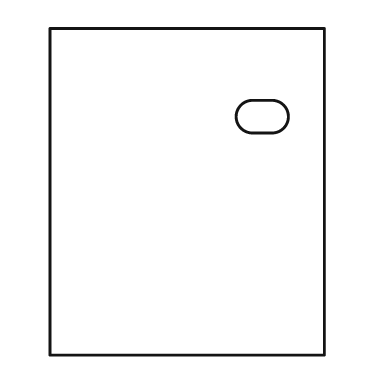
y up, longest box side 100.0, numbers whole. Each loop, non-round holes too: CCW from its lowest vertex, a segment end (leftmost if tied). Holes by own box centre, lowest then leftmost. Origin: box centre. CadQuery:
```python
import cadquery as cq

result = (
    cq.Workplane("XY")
    .moveTo(-42.0, -50.0)
    .lineTo(42.0, -50.0)
    .lineTo(42.0, 50.0)
    .lineTo(-42.0, 50.0)
    .close()
    .moveTo(20.0, 18.0)
    .lineTo(26.0, 18.0)
    .threePointArc((31.0, 23.0), (26.0, 28.0))
    .lineTo(20.0, 28.0)
    .threePointArc((15.0, 23.0), (20.0, 18.0))
    .close()
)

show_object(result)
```